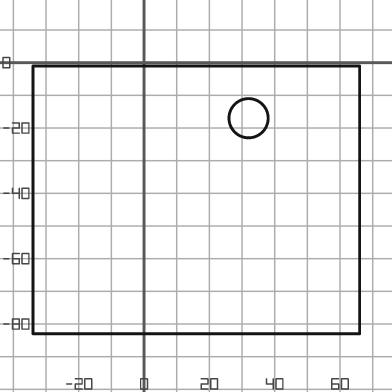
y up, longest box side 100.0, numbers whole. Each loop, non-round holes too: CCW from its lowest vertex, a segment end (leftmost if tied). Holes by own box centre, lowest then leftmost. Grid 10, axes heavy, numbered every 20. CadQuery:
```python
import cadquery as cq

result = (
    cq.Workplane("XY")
    .moveTo(-34.0, -83.0)
    .lineTo(66.0, -83.0)
    .lineTo(66.0, -1.0)
    .lineTo(-34.0, -1.0)
    .close()
    .moveTo(32.0, -17.0)
    .circle(6.0)
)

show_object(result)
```